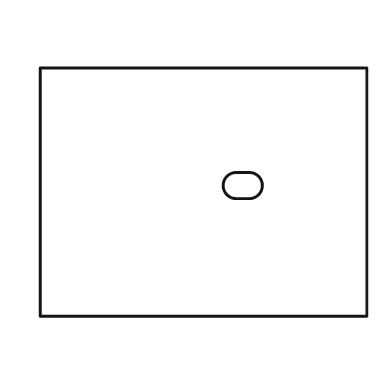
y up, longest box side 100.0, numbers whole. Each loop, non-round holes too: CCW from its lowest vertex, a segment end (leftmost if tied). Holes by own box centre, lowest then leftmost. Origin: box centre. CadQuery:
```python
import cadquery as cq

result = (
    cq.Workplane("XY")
    .moveTo(-50.0, -38.0)
    .lineTo(50.0, -38.0)
    .lineTo(50.0, 38.0)
    .lineTo(-50.0, 38.0)
    .close()
    .moveTo(10.0, -2.0)
    .lineTo(14.0, -2.0)
    .threePointArc((18.0, 2.0), (14.0, 6.0))
    .lineTo(10.0, 6.0)
    .threePointArc((6.0, 2.0), (10.0, -2.0))
    .close()
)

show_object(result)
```